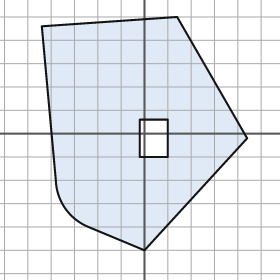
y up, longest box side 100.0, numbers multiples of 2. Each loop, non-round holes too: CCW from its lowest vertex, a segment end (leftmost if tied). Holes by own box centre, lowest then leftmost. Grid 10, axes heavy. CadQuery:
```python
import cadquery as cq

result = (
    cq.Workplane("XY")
    .moveTo(0.0, -50.0)
    .lineTo(44.0, -2.0)
    .lineTo(14.0, 50.0)
    .lineTo(-44.0, 46.0)
    .lineTo(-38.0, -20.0)
    .threePointArc((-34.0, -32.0), (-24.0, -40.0))
    .close()
    .moveTo(-2.0, -10.0)
    .lineTo(10.0, -10.0)
    .lineTo(10.0, 6.0)
    .lineTo(-2.0, 6.0)
    .close()
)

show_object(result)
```